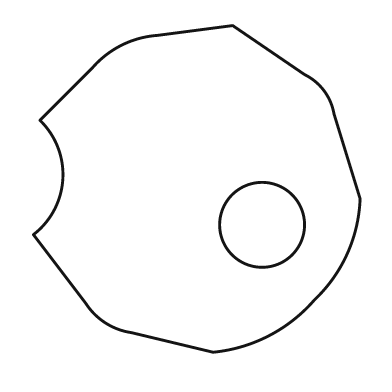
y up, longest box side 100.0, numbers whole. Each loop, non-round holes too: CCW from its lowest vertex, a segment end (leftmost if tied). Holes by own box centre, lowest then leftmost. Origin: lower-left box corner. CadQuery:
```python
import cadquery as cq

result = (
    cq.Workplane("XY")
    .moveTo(55.0, 0.0)
    .threePointArc((72.0, 5.0), (86.0, 16.0))
    .threePointArc((96.0, 30.0), (100.0, 47.0))
    .lineTo(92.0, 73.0)
    .threePointArc((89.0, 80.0), (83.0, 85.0))
    .lineTo(61.0, 100.0)
    .lineTo(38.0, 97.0)
    .threePointArc((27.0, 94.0), (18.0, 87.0))
    .lineTo(2.0, 71.0)
    .threePointArc((9.0, 53.0), (0.0, 36.0))
    .lineTo(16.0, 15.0)
    .threePointArc((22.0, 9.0), (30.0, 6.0))
    .close()
    .moveTo(70.0, 39.0)
    .circle(13.0)
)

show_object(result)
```